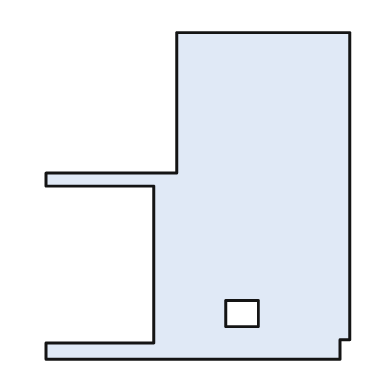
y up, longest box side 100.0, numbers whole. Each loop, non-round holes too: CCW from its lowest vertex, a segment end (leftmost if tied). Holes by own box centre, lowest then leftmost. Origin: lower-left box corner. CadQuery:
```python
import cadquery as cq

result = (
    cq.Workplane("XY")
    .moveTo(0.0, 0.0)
    .lineTo(90.0, 0.0)
    .lineTo(90.0, 6.0)
    .lineTo(93.0, 6.0)
    .lineTo(93.0, 100.0)
    .lineTo(40.0, 100.0)
    .lineTo(40.0, 57.0)
    .lineTo(0.0, 57.0)
    .lineTo(0.0, 53.0)
    .lineTo(33.0, 53.0)
    .lineTo(33.0, 5.0)
    .lineTo(0.0, 5.0)
    .close()
    .moveTo(55.0, 10.0)
    .lineTo(65.0, 10.0)
    .lineTo(65.0, 18.0)
    .lineTo(55.0, 18.0)
    .close()
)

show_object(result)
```